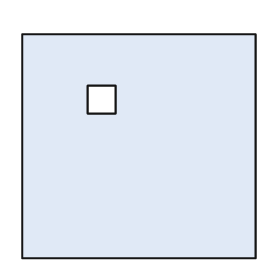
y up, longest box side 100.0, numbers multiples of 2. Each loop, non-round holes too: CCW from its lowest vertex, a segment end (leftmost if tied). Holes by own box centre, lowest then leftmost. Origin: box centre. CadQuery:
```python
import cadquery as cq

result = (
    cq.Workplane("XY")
    .moveTo(-50.0, -48.0)
    .lineTo(50.0, -48.0)
    .lineTo(50.0, 48.0)
    .lineTo(-50.0, 48.0)
    .close()
    .moveTo(-22.0, 14.0)
    .lineTo(-10.0, 14.0)
    .lineTo(-10.0, 26.0)
    .lineTo(-22.0, 26.0)
    .close()
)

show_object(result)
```